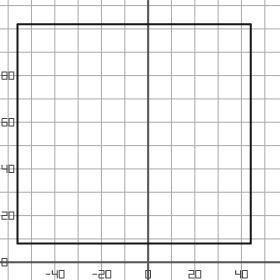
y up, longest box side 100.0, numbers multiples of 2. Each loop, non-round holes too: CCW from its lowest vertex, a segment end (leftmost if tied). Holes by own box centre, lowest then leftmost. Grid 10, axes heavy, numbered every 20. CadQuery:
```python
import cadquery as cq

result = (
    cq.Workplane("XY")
    .moveTo(-56.0, 8.0)
    .lineTo(44.0, 8.0)
    .lineTo(44.0, 102.0)
    .lineTo(-56.0, 102.0)
    .close()
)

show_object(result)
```